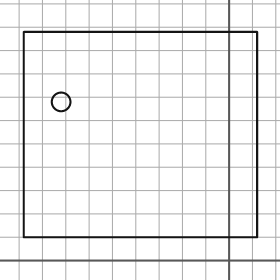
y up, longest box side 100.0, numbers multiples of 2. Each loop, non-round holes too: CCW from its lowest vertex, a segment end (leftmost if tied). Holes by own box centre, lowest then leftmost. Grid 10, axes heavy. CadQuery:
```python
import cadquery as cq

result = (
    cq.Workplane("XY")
    .moveTo(-88.0, 10.0)
    .lineTo(12.0, 10.0)
    .lineTo(12.0, 98.0)
    .lineTo(-88.0, 98.0)
    .close()
    .moveTo(-72.0, 68.0)
    .circle(4.0)
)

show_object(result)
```